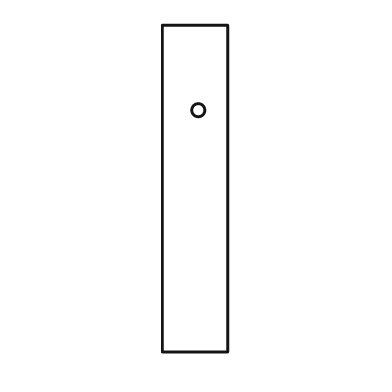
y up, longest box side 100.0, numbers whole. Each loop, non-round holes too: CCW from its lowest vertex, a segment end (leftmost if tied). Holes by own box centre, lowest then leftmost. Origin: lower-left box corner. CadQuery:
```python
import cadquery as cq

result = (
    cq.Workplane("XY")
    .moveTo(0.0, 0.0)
    .lineTo(20.0, 0.0)
    .lineTo(20.0, 100.0)
    .lineTo(0.0, 100.0)
    .close()
    .moveTo(11.0, 74.0)
    .circle(2.0)
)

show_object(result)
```